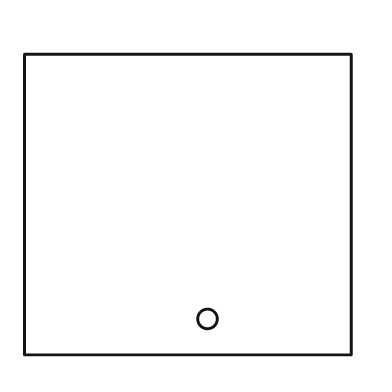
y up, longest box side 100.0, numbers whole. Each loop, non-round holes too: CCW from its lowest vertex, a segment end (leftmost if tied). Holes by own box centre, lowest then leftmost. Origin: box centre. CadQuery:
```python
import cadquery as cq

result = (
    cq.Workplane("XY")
    .moveTo(-50.0, -46.0)
    .lineTo(50.0, -46.0)
    .lineTo(50.0, 46.0)
    .lineTo(-50.0, 46.0)
    .close()
    .moveTo(6.0, -35.0)
    .circle(3.0)
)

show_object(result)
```